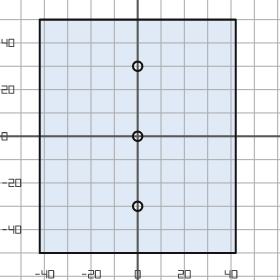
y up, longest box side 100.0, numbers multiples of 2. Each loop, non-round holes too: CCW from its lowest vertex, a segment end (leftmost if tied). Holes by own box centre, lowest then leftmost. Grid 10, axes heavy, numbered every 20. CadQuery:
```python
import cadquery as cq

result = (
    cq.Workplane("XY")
    .moveTo(-42.0, -50.0)
    .lineTo(42.0, -50.0)
    .lineTo(42.0, 50.0)
    .lineTo(-42.0, 50.0)
    .close()
    .moveTo(0.0, -30.0)
    .circle(2.0)
    .moveTo(0.0, 0.0)
    .circle(2.0)
    .moveTo(0.0, 30.0)
    .circle(2.0)
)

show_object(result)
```